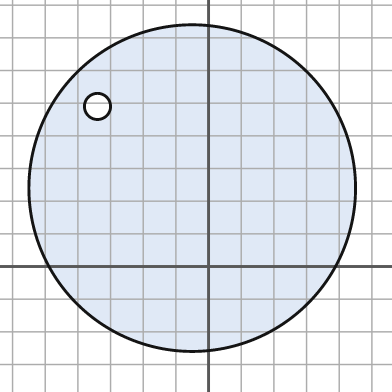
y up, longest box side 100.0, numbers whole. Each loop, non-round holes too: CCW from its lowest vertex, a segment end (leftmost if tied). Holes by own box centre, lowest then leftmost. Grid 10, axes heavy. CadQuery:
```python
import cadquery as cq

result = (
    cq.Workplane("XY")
    .moveTo(-5.0, 24.0)
    .circle(50.0)
    .moveTo(-34.0, 49.0)
    .circle(4.0)
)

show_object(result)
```